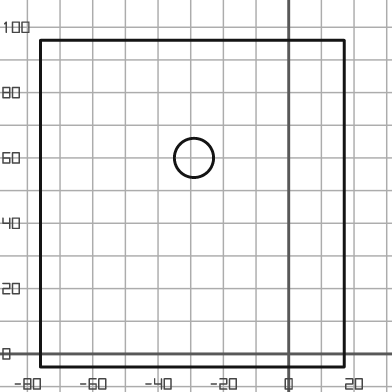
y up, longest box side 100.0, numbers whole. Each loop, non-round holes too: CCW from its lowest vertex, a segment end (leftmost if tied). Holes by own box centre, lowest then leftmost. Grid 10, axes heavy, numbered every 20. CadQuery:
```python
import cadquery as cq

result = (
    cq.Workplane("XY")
    .moveTo(-76.0, -4.0)
    .lineTo(17.0, -4.0)
    .lineTo(17.0, 96.0)
    .lineTo(-76.0, 96.0)
    .close()
    .moveTo(-29.0, 60.0)
    .circle(6.0)
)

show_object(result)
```